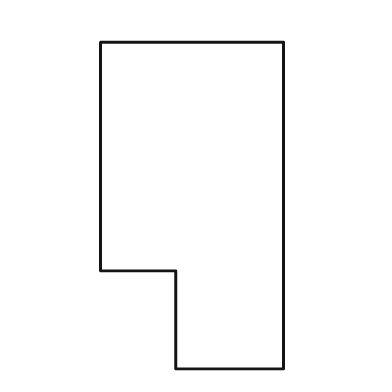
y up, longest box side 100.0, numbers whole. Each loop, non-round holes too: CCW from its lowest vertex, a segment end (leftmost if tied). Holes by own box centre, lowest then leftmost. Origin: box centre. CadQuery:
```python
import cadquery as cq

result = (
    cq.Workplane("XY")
    .moveTo(-5.0, -50.0)
    .lineTo(28.0, -50.0)
    .lineTo(28.0, 50.0)
    .lineTo(-28.0, 50.0)
    .lineTo(-28.0, -20.0)
    .lineTo(-5.0, -20.0)
    .close()
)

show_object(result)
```